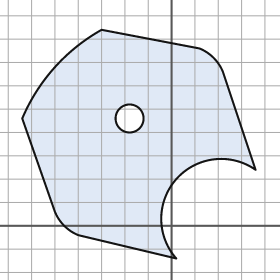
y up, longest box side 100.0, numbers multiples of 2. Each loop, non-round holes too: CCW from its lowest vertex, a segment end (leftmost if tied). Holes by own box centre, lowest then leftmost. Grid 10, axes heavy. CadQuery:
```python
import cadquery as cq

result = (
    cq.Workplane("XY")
    .moveTo(2.0, -14.0)
    .threePointArc((2.0, 20.0), (36.0, 24.0))
    .lineTo(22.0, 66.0)
    .threePointArc((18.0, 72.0), (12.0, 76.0))
    .lineTo(-30.0, 84.0)
    .threePointArc((-50.0, 68.0), (-64.0, 46.0))
    .lineTo(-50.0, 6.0)
    .threePointArc((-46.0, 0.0), (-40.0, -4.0))
    .close()
    .moveTo(-18.0, 46.0)
    .circle(6.0)
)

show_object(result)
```